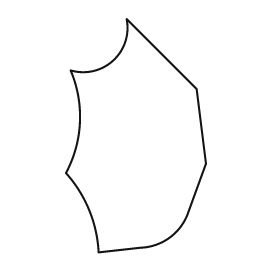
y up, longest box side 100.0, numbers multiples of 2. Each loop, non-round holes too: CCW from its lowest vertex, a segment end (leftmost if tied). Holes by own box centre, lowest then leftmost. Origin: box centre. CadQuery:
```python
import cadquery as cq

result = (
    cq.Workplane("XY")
    .moveTo(-16.0, -50.0)
    .lineTo(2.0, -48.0)
    .threePointArc((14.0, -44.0), (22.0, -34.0))
    .lineTo(30.0, -12.0)
    .lineTo(26.0, 20.0)
    .lineTo(-4.0, 50.0)
    .threePointArc((-10.0, 32.0), (-28.0, 28.0))
    .threePointArc((-24.0, 6.0), (-30.0, -16.0))
    .threePointArc((-20.0, -32.0), (-16.0, -50.0))
    .close()
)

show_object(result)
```